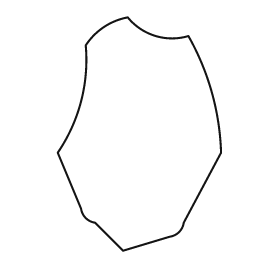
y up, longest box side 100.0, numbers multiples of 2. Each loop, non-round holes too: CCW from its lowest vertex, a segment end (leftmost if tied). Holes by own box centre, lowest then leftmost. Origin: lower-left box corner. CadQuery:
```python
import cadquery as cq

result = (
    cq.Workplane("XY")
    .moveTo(28.0, 0.0)
    .lineTo(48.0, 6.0)
    .threePointArc((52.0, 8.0), (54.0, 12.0))
    .lineTo(70.0, 42.0)
    .threePointArc((66.0, 68.0), (56.0, 92.0))
    .threePointArc((42.0, 92.0), (30.0, 100.0))
    .threePointArc((20.0, 96.0), (12.0, 88.0))
    .threePointArc((10.0, 64.0), (0.0, 42.0))
    .lineTo(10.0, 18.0)
    .threePointArc((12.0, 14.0), (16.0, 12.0))
    .close()
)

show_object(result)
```